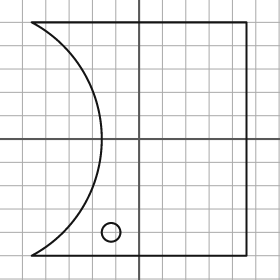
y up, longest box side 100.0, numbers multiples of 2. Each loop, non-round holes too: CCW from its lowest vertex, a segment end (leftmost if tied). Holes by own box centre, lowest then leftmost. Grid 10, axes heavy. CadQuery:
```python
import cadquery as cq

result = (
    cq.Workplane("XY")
    .moveTo(-46.0, -50.0)
    .lineTo(46.0, -50.0)
    .lineTo(46.0, 50.0)
    .lineTo(-46.0, 50.0)
    .threePointArc((-16.0, 0.0), (-46.0, -50.0))
    .close()
    .moveTo(-12.0, -40.0)
    .circle(4.0)
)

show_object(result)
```